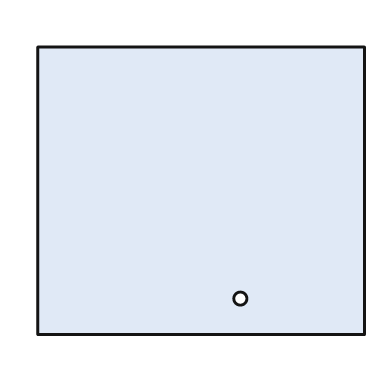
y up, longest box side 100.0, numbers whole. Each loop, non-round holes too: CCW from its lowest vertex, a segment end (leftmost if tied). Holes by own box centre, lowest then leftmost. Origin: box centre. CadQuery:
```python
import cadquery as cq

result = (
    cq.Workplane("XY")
    .moveTo(-50.0, -44.0)
    .lineTo(50.0, -44.0)
    .lineTo(50.0, 44.0)
    .lineTo(-50.0, 44.0)
    .close()
    .moveTo(12.0, -33.0)
    .circle(2.0)
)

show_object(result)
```